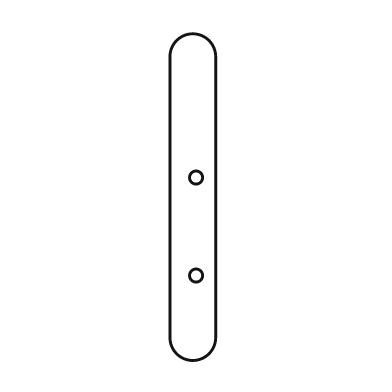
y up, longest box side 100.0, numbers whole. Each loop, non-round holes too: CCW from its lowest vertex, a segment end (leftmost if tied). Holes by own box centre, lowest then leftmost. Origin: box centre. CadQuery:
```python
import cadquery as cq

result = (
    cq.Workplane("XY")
    .moveTo(-7.0, -43.0)
    .threePointArc((0.0, -50.0), (7.0, -43.0))
    .lineTo(7.0, 43.0)
    .threePointArc((0.0, 50.0), (-7.0, 43.0))
    .close()
    .moveTo(1.0, -24.0)
    .circle(2.0)
    .moveTo(1.0, 6.0)
    .circle(2.0)
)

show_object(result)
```